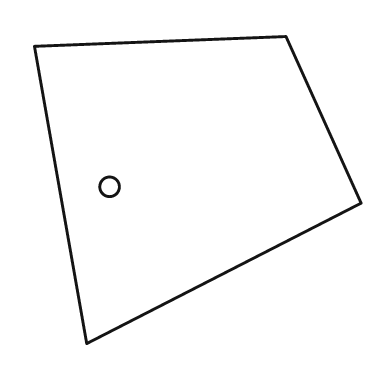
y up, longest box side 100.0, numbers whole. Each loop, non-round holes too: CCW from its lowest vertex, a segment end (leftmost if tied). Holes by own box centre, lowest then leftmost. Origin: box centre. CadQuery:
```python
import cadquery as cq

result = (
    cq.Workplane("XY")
    .moveTo(-34.0, -47.0)
    .lineTo(50.0, -4.0)
    .lineTo(27.0, 47.0)
    .lineTo(-50.0, 44.0)
    .close()
    .moveTo(-27.0, 1.0)
    .circle(3.0)
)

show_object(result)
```